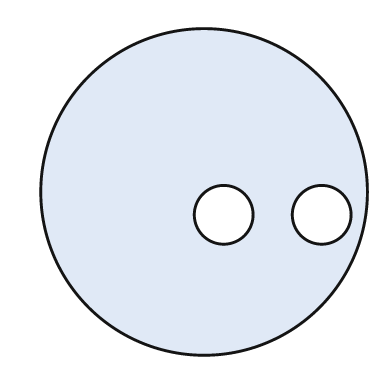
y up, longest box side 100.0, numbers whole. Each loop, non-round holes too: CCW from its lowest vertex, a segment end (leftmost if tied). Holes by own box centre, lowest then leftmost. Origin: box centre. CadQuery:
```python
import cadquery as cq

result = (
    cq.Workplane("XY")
    .moveTo(0.0, 0.0)
    .circle(50.0)
    .moveTo(6.0, -7.0)
    .circle(9.0)
    .moveTo(36.0, -7.0)
    .circle(9.0)
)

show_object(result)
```